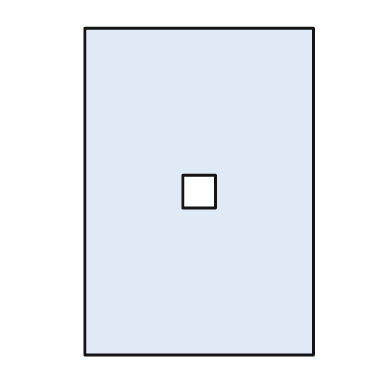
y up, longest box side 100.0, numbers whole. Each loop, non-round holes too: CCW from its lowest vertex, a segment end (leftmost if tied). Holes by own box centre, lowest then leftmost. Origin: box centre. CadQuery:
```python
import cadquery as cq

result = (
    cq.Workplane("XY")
    .moveTo(-35.0, -50.0)
    .lineTo(35.0, -50.0)
    .lineTo(35.0, 50.0)
    .lineTo(-35.0, 50.0)
    .close()
    .moveTo(-5.0, -5.0)
    .lineTo(5.0, -5.0)
    .lineTo(5.0, 5.0)
    .lineTo(-5.0, 5.0)
    .close()
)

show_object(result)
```